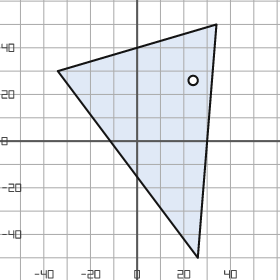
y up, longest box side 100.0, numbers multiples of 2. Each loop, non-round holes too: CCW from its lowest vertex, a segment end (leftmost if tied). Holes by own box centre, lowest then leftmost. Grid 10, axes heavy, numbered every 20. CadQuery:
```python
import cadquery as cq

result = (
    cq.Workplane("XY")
    .moveTo(26.0, -50.0)
    .lineTo(34.0, 50.0)
    .lineTo(-34.0, 30.0)
    .close()
    .moveTo(24.0, 26.0)
    .circle(2.0)
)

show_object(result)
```